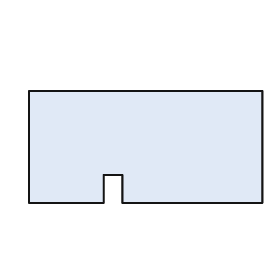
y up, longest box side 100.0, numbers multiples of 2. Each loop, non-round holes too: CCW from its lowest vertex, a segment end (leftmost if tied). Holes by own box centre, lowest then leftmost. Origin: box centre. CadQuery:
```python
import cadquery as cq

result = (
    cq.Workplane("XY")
    .moveTo(-50.0, -24.0)
    .lineTo(-18.0, -24.0)
    .lineTo(-18.0, -12.0)
    .lineTo(-10.0, -12.0)
    .lineTo(-10.0, -24.0)
    .lineTo(50.0, -24.0)
    .lineTo(50.0, 24.0)
    .lineTo(-50.0, 24.0)
    .close()
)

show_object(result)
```